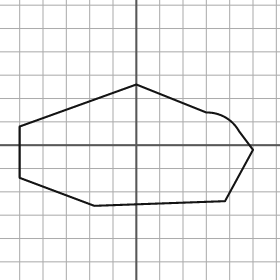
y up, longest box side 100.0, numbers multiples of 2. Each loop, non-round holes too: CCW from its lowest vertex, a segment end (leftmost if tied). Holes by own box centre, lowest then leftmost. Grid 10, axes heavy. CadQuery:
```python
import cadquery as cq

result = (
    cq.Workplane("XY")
    .moveTo(-18.0, -26.0)
    .lineTo(38.0, -24.0)
    .lineTo(50.0, -2.0)
    .lineTo(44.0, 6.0)
    .threePointArc((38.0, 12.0), (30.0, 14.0))
    .lineTo(0.0, 26.0)
    .lineTo(-50.0, 8.0)
    .lineTo(-50.0, -14.0)
    .close()
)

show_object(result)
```